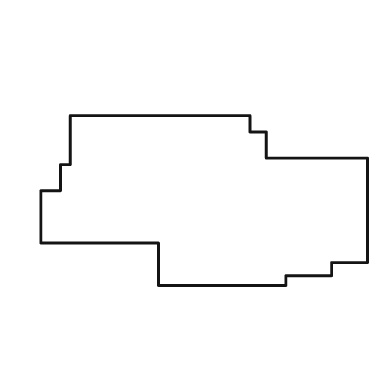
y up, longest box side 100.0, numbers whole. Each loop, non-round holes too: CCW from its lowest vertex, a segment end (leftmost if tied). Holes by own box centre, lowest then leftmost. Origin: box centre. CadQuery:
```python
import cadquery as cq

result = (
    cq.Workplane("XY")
    .moveTo(-14.0, -26.0)
    .lineTo(25.0, -26.0)
    .lineTo(25.0, -23.0)
    .lineTo(39.0, -23.0)
    .lineTo(39.0, -19.0)
    .lineTo(50.0, -19.0)
    .lineTo(50.0, 13.0)
    .lineTo(19.0, 13.0)
    .lineTo(19.0, 21.0)
    .lineTo(14.0, 21.0)
    .lineTo(14.0, 26.0)
    .lineTo(-41.0, 26.0)
    .lineTo(-41.0, 11.0)
    .lineTo(-44.0, 11.0)
    .lineTo(-44.0, 3.0)
    .lineTo(-50.0, 3.0)
    .lineTo(-50.0, -13.0)
    .lineTo(-14.0, -13.0)
    .close()
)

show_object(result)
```